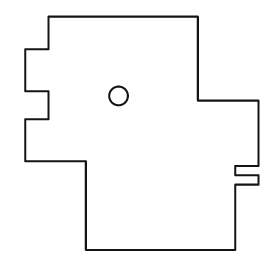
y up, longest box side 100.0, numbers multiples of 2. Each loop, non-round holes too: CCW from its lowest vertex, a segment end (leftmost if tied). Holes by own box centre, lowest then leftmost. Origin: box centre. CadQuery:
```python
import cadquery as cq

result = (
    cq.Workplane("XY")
    .moveTo(-24.0, -50.0)
    .lineTo(40.0, -50.0)
    .lineTo(40.0, -22.0)
    .lineTo(50.0, -22.0)
    .lineTo(50.0, -18.0)
    .lineTo(40.0, -18.0)
    .lineTo(40.0, -14.0)
    .lineTo(50.0, -14.0)
    .lineTo(50.0, 14.0)
    .lineTo(24.0, 14.0)
    .lineTo(24.0, 50.0)
    .lineTo(-40.0, 50.0)
    .lineTo(-40.0, 36.0)
    .lineTo(-50.0, 36.0)
    .lineTo(-50.0, 18.0)
    .lineTo(-40.0, 18.0)
    .lineTo(-40.0, 6.0)
    .lineTo(-50.0, 6.0)
    .lineTo(-50.0, -12.0)
    .lineTo(-24.0, -12.0)
    .close()
    .moveTo(-10.0, 16.0)
    .circle(4.0)
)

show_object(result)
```